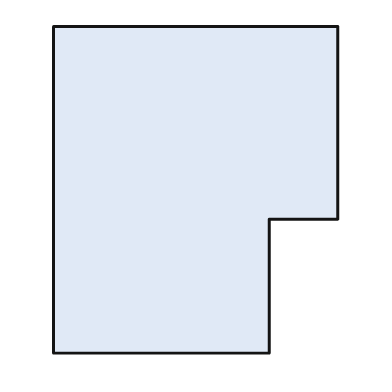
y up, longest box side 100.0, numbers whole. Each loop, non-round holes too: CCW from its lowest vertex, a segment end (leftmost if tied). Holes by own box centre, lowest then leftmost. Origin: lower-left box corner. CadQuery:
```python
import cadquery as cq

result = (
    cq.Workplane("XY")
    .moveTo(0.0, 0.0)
    .lineTo(66.0, 0.0)
    .lineTo(66.0, 41.0)
    .lineTo(87.0, 41.0)
    .lineTo(87.0, 100.0)
    .lineTo(0.0, 100.0)
    .close()
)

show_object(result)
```